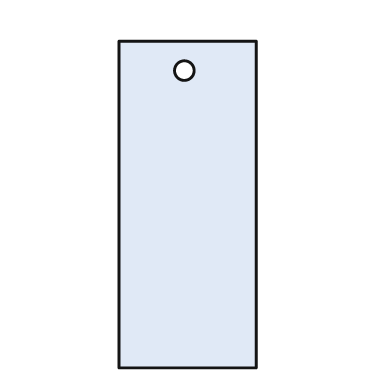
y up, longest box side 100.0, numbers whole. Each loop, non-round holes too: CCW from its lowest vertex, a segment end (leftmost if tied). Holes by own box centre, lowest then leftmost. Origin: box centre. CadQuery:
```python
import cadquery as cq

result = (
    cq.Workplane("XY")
    .moveTo(-21.0, -50.0)
    .lineTo(21.0, -50.0)
    .lineTo(21.0, 50.0)
    .lineTo(-21.0, 50.0)
    .close()
    .moveTo(-1.0, 41.0)
    .circle(3.0)
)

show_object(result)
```